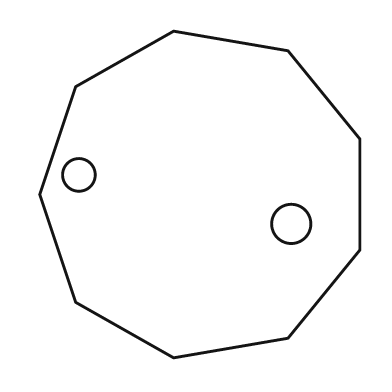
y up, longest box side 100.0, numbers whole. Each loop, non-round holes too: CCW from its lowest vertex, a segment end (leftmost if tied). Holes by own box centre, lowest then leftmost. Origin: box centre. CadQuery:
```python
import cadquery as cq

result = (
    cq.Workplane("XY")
    .moveTo(-8.0, -50.0)
    .lineTo(27.0, -44.0)
    .lineTo(49.0, -17.0)
    .lineTo(49.0, 17.0)
    .lineTo(27.0, 44.0)
    .lineTo(-8.0, 50.0)
    .lineTo(-38.0, 33.0)
    .lineTo(-49.0, 0.0)
    .lineTo(-38.0, -33.0)
    .close()
    .moveTo(28.0, -9.0)
    .circle(6.0)
    .moveTo(-37.0, 6.0)
    .circle(5.0)
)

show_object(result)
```